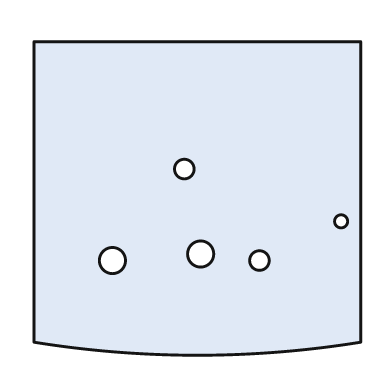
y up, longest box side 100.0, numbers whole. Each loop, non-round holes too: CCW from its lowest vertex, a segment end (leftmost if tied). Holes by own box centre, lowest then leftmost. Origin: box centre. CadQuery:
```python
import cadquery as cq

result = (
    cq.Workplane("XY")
    .moveTo(-50.0, -44.0)
    .threePointArc((0.0, -48.0), (50.0, -44.0))
    .lineTo(50.0, 48.0)
    .lineTo(-50.0, 48.0)
    .close()
    .moveTo(-26.0, -19.0)
    .circle(4.0)
    .moveTo(19.0, -19.0)
    .circle(3.0)
    .moveTo(1.0, -17.0)
    .circle(4.0)
    .moveTo(44.0, -7.0)
    .circle(2.0)
    .moveTo(-4.0, 9.0)
    .circle(3.0)
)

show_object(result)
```